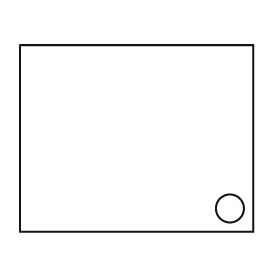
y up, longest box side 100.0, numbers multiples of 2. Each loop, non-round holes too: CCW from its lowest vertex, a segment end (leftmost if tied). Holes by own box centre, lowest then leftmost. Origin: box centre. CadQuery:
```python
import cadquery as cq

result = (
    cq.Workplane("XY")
    .moveTo(-50.0, -40.0)
    .lineTo(50.0, -40.0)
    .lineTo(50.0, 40.0)
    .lineTo(-50.0, 40.0)
    .close()
    .moveTo(40.0, -30.0)
    .circle(6.0)
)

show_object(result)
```